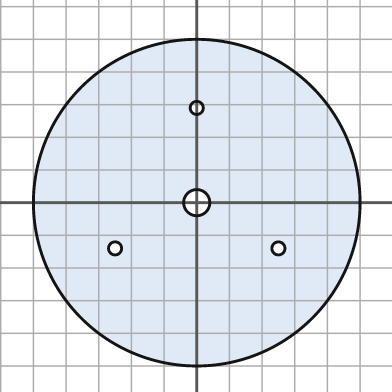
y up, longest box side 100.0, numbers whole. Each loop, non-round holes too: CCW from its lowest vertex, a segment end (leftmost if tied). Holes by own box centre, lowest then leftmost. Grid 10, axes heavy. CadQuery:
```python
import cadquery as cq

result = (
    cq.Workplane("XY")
    .moveTo(0.0, 0.0)
    .circle(50.0)
    .moveTo(-25.0, -14.0)
    .circle(2.0)
    .moveTo(25.0, -14.0)
    .circle(2.0)
    .moveTo(0.0, 0.0)
    .circle(4.0)
    .moveTo(0.0, 29.0)
    .circle(2.0)
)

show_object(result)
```